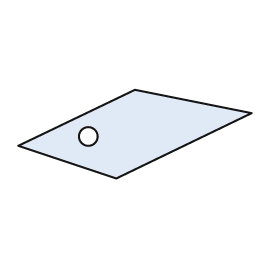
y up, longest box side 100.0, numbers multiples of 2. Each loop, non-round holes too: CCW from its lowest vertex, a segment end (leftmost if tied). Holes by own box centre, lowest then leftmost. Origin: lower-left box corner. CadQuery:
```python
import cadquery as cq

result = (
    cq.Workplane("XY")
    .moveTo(42.0, 0.0)
    .lineTo(100.0, 28.0)
    .lineTo(50.0, 38.0)
    .lineTo(0.0, 14.0)
    .close()
    .moveTo(30.0, 18.0)
    .circle(4.0)
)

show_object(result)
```